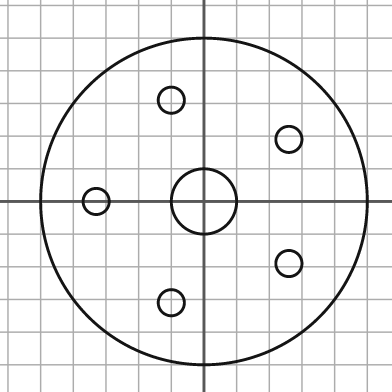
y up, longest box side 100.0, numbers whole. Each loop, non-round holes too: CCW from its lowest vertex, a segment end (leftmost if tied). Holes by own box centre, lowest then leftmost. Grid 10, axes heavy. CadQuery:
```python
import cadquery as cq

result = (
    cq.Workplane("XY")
    .moveTo(0.0, 0.0)
    .circle(50.0)
    .moveTo(-10.0, -31.0)
    .circle(4.0)
    .moveTo(26.0, -19.0)
    .circle(4.0)
    .moveTo(-33.0, 0.0)
    .circle(4.0)
    .moveTo(0.0, 0.0)
    .circle(10.0)
    .moveTo(26.0, 19.0)
    .circle(4.0)
    .moveTo(-10.0, 31.0)
    .circle(4.0)
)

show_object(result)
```